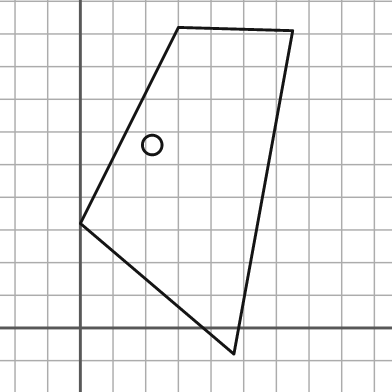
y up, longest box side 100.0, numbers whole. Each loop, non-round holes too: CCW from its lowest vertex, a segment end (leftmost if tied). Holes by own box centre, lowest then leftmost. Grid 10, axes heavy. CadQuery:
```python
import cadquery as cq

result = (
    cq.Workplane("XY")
    .moveTo(47.0, -8.0)
    .lineTo(65.0, 91.0)
    .lineTo(30.0, 92.0)
    .lineTo(0.0, 32.0)
    .close()
    .moveTo(22.0, 56.0)
    .circle(3.0)
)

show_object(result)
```